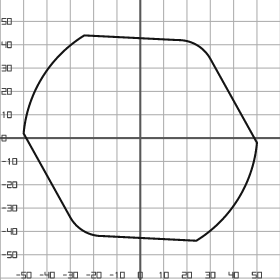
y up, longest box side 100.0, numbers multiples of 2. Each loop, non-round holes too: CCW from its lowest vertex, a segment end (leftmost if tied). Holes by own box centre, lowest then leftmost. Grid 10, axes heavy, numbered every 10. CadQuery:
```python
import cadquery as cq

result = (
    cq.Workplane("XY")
    .moveTo(24.0, -44.0)
    .threePointArc((42.0, -26.0), (50.0, -2.0))
    .lineTo(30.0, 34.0)
    .threePointArc((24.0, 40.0), (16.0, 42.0))
    .lineTo(-24.0, 44.0)
    .threePointArc((-42.0, 26.0), (-50.0, 2.0))
    .lineTo(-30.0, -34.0)
    .threePointArc((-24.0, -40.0), (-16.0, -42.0))
    .close()
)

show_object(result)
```